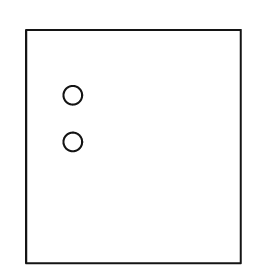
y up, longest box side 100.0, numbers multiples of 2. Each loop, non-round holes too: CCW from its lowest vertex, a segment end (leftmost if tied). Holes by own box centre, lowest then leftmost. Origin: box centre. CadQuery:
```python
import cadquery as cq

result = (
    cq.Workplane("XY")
    .moveTo(-46.0, -50.0)
    .lineTo(46.0, -50.0)
    .lineTo(46.0, 50.0)
    .lineTo(-46.0, 50.0)
    .close()
    .moveTo(-26.0, 2.0)
    .circle(4.0)
    .moveTo(-26.0, 22.0)
    .circle(4.0)
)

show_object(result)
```